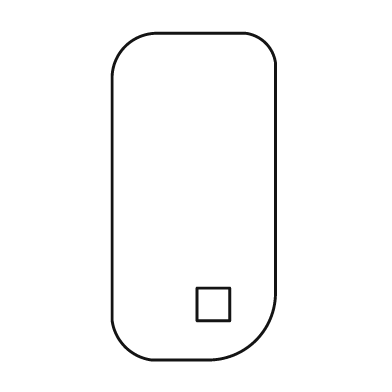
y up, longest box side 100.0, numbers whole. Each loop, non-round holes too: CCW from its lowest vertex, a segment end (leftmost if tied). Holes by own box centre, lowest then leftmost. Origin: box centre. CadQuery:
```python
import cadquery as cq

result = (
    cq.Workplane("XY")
    .moveTo(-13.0, -50.0)
    .lineTo(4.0, -50.0)
    .threePointArc((19.0, -44.0), (25.0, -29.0))
    .lineTo(25.0, 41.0)
    .threePointArc((22.0, 47.0), (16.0, 50.0))
    .lineTo(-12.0, 50.0)
    .threePointArc((-21.0, 46.0), (-25.0, 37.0))
    .lineTo(-25.0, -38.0)
    .threePointArc((-21.0, -46.0), (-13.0, -50.0))
    .close()
    .moveTo(1.0, -38.0)
    .lineTo(11.0, -38.0)
    .lineTo(11.0, -28.0)
    .lineTo(1.0, -28.0)
    .close()
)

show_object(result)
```